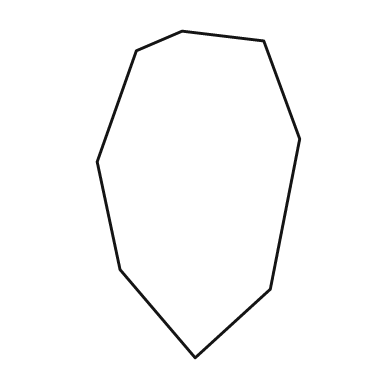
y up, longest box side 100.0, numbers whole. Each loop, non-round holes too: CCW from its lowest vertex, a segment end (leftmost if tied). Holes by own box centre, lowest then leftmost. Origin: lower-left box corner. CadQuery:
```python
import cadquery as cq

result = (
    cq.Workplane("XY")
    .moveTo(30.0, 0.0)
    .lineTo(53.0, 21.0)
    .lineTo(62.0, 67.0)
    .lineTo(51.0, 97.0)
    .lineTo(26.0, 100.0)
    .lineTo(12.0, 94.0)
    .lineTo(0.0, 60.0)
    .lineTo(7.0, 27.0)
    .close()
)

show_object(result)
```